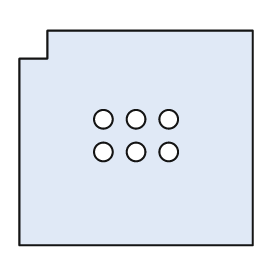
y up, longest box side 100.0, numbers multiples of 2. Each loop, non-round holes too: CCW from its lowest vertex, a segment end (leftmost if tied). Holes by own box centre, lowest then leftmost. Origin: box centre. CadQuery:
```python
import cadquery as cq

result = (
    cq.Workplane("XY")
    .moveTo(-50.0, -46.0)
    .lineTo(50.0, -46.0)
    .lineTo(50.0, 46.0)
    .lineTo(-38.0, 46.0)
    .lineTo(-38.0, 34.0)
    .lineTo(-50.0, 34.0)
    .close()
    .moveTo(-14.0, -6.0)
    .circle(4.0)
    .moveTo(0.0, -6.0)
    .circle(4.0)
    .moveTo(14.0, -6.0)
    .circle(4.0)
    .moveTo(-14.0, 8.0)
    .circle(4.0)
    .moveTo(0.0, 8.0)
    .circle(4.0)
    .moveTo(14.0, 8.0)
    .circle(4.0)
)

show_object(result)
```